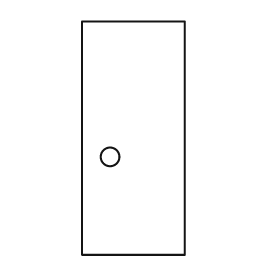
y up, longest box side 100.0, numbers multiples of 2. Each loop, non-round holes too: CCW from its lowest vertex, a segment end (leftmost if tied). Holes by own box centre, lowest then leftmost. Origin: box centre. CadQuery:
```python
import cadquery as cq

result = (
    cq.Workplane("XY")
    .moveTo(-22.0, -50.0)
    .lineTo(22.0, -50.0)
    .lineTo(22.0, 50.0)
    .lineTo(-22.0, 50.0)
    .close()
    .moveTo(-10.0, -8.0)
    .circle(4.0)
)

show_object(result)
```